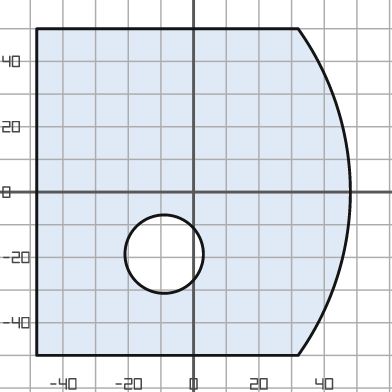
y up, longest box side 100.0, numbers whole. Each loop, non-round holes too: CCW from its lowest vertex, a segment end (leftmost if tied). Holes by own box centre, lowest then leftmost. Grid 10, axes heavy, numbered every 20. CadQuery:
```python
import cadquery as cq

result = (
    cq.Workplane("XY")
    .moveTo(-48.0, -50.0)
    .lineTo(32.0, -50.0)
    .threePointArc((48.0, 0.0), (32.0, 50.0))
    .lineTo(-48.0, 50.0)
    .close()
    .moveTo(-9.0, -19.0)
    .circle(12.0)
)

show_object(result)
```